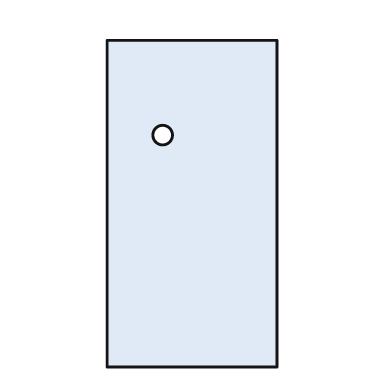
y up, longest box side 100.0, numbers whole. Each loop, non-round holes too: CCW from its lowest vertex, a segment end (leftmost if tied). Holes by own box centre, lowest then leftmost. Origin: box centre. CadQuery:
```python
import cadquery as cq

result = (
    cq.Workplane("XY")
    .moveTo(-26.0, -50.0)
    .lineTo(26.0, -50.0)
    .lineTo(26.0, 50.0)
    .lineTo(-26.0, 50.0)
    .close()
    .moveTo(-9.0, 21.0)
    .circle(3.0)
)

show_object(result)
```